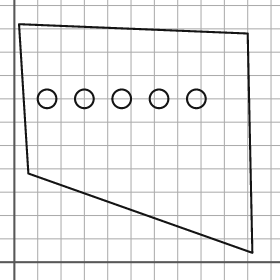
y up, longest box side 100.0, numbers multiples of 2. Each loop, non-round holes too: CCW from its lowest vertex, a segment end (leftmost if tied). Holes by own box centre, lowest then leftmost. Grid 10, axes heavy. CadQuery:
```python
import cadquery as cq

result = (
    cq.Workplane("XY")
    .moveTo(102.0, 4.0)
    .lineTo(100.0, 98.0)
    .lineTo(2.0, 102.0)
    .lineTo(6.0, 38.0)
    .close()
    .moveTo(14.0, 70.0)
    .circle(4.0)
    .moveTo(30.0, 70.0)
    .circle(4.0)
    .moveTo(46.0, 70.0)
    .circle(4.0)
    .moveTo(62.0, 70.0)
    .circle(4.0)
    .moveTo(78.0, 70.0)
    .circle(4.0)
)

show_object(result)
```